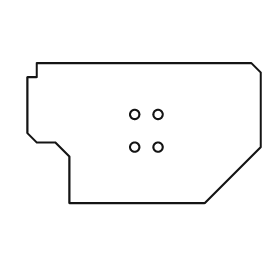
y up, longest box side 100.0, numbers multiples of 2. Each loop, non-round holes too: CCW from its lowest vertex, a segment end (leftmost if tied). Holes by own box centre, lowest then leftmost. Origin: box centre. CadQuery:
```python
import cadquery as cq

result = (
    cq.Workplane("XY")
    .moveTo(-32.0, -30.0)
    .lineTo(26.0, -30.0)
    .lineTo(50.0, -6.0)
    .lineTo(50.0, 26.0)
    .lineTo(46.0, 30.0)
    .lineTo(-46.0, 30.0)
    .lineTo(-46.0, 24.0)
    .lineTo(-50.0, 24.0)
    .lineTo(-50.0, 0.0)
    .lineTo(-46.0, -4.0)
    .lineTo(-38.0, -4.0)
    .lineTo(-32.0, -10.0)
    .close()
    .moveTo(-4.0, -6.0)
    .circle(2.0)
    .moveTo(6.0, -6.0)
    .circle(2.0)
    .moveTo(-4.0, 8.0)
    .circle(2.0)
    .moveTo(6.0, 8.0)
    .circle(2.0)
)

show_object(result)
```